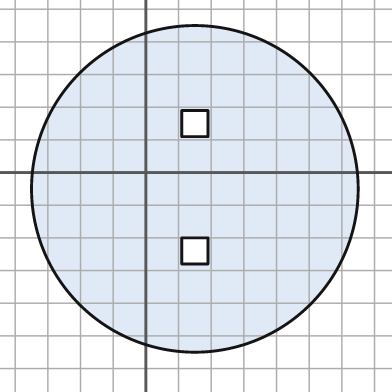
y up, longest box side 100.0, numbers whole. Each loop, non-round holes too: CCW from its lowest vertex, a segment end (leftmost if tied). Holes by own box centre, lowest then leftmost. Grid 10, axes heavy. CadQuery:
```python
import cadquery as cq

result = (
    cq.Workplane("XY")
    .moveTo(15.0, -5.0)
    .circle(50.0)
    .moveTo(11.0, -28.0)
    .lineTo(19.0, -28.0)
    .lineTo(19.0, -20.0)
    .lineTo(11.0, -20.0)
    .close()
    .moveTo(11.0, 11.0)
    .lineTo(19.0, 11.0)
    .lineTo(19.0, 19.0)
    .lineTo(11.0, 19.0)
    .close()
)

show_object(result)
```